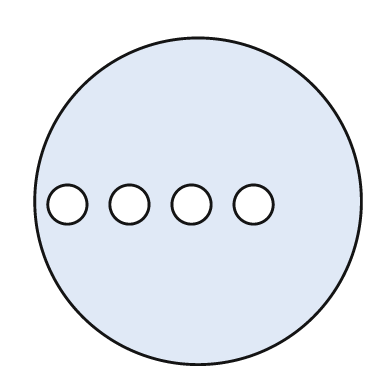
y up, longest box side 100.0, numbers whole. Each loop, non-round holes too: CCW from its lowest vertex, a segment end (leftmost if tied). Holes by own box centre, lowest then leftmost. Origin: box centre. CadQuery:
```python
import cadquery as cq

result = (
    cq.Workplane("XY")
    .moveTo(0.0, 0.0)
    .circle(50.0)
    .moveTo(-40.0, -1.0)
    .circle(6.0)
    .moveTo(-21.0, -1.0)
    .circle(6.0)
    .moveTo(-2.0, -1.0)
    .circle(6.0)
    .moveTo(17.0, -1.0)
    .circle(6.0)
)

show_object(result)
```